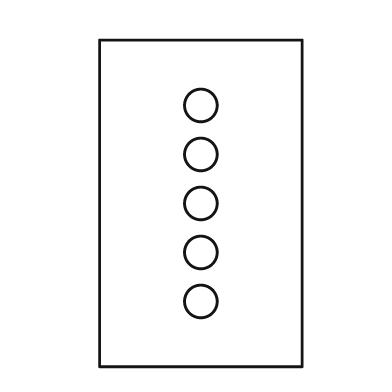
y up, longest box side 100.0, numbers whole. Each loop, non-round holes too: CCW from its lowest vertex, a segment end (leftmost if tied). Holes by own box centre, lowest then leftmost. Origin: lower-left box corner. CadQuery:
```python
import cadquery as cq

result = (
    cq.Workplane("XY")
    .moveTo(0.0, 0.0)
    .lineTo(62.0, 0.0)
    .lineTo(62.0, 100.0)
    .lineTo(0.0, 100.0)
    .close()
    .moveTo(31.0, 20.0)
    .circle(5.0)
    .moveTo(31.0, 35.0)
    .circle(5.0)
    .moveTo(31.0, 50.0)
    .circle(5.0)
    .moveTo(31.0, 65.0)
    .circle(5.0)
    .moveTo(31.0, 80.0)
    .circle(5.0)
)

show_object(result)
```